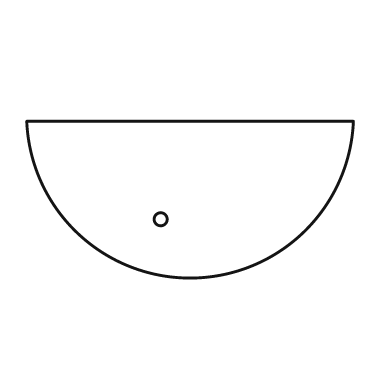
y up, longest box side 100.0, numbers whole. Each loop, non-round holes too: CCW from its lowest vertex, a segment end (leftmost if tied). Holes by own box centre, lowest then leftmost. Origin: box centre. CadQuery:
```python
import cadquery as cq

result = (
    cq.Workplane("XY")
    .moveTo(-50.0, 24.0)
    .threePointArc((0.0, -24.0), (50.0, 24.0))
    .close()
    .moveTo(-9.0, -6.0)
    .circle(2.0)
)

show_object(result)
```